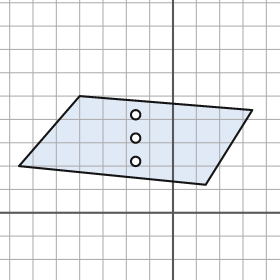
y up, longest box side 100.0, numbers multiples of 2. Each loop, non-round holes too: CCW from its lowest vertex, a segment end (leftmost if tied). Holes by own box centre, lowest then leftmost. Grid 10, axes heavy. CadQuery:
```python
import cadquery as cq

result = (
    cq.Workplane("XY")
    .moveTo(14.0, 12.0)
    .lineTo(34.0, 44.0)
    .lineTo(-40.0, 50.0)
    .lineTo(-66.0, 20.0)
    .close()
    .moveTo(-16.0, 22.0)
    .circle(2.0)
    .moveTo(-16.0, 32.0)
    .circle(2.0)
    .moveTo(-16.0, 42.0)
    .circle(2.0)
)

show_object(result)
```